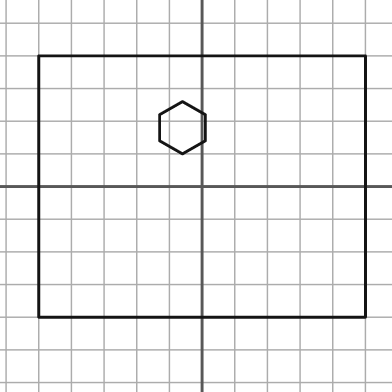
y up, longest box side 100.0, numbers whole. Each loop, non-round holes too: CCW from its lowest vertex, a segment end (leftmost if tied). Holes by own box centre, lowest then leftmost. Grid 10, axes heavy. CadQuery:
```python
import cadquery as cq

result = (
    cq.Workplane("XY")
    .moveTo(-50.0, -40.0)
    .lineTo(50.0, -40.0)
    .lineTo(50.0, 40.0)
    .lineTo(-50.0, 40.0)
    .close()
    .moveTo(-6.0, 10.0)
    .lineTo(1.0, 14.0)
    .lineTo(1.0, 22.0)
    .lineTo(-6.0, 26.0)
    .lineTo(-13.0, 22.0)
    .lineTo(-13.0, 14.0)
    .close()
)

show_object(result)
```